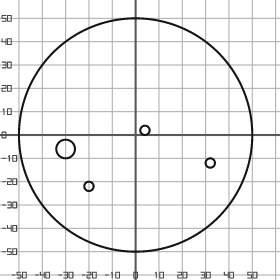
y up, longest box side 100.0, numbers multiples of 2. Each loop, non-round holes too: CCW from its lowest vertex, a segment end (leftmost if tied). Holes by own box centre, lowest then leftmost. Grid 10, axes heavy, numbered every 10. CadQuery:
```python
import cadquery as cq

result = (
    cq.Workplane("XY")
    .moveTo(0.0, 0.0)
    .circle(50.0)
    .moveTo(-20.0, -22.0)
    .circle(2.0)
    .moveTo(32.0, -12.0)
    .circle(2.0)
    .moveTo(-30.0, -6.0)
    .circle(4.0)
    .moveTo(4.0, 2.0)
    .circle(2.0)
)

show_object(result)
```